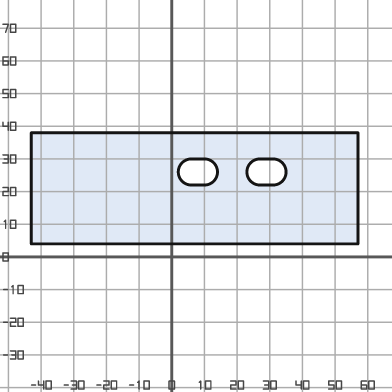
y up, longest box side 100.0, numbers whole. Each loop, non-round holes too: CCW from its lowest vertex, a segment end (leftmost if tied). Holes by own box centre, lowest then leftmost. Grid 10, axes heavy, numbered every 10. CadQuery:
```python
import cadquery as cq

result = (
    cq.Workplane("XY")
    .moveTo(-43.0, 4.0)
    .lineTo(57.0, 4.0)
    .lineTo(57.0, 38.0)
    .lineTo(-43.0, 38.0)
    .close()
    .moveTo(6.0, 22.0)
    .lineTo(10.0, 22.0)
    .threePointArc((14.0, 26.0), (10.0, 30.0))
    .lineTo(6.0, 30.0)
    .threePointArc((2.0, 26.0), (6.0, 22.0))
    .close()
    .moveTo(27.0, 22.0)
    .lineTo(31.0, 22.0)
    .threePointArc((35.0, 26.0), (31.0, 30.0))
    .lineTo(27.0, 30.0)
    .threePointArc((23.0, 26.0), (27.0, 22.0))
    .close()
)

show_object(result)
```